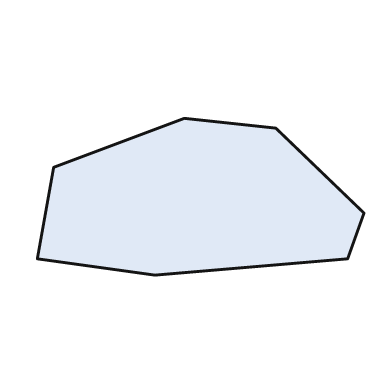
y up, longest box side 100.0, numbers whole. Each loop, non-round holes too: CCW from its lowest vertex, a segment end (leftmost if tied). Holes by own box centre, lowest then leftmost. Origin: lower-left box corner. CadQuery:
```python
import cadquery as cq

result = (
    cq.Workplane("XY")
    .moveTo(36.0, 0.0)
    .lineTo(95.0, 5.0)
    .lineTo(100.0, 19.0)
    .lineTo(73.0, 45.0)
    .lineTo(45.0, 48.0)
    .lineTo(5.0, 33.0)
    .lineTo(0.0, 5.0)
    .close()
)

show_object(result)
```